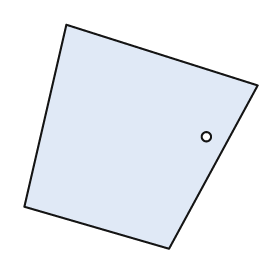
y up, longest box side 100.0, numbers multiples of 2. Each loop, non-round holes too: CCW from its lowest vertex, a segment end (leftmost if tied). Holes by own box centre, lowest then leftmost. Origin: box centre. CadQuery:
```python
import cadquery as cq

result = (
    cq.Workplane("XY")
    .moveTo(12.0, -48.0)
    .lineTo(50.0, 22.0)
    .lineTo(-32.0, 48.0)
    .lineTo(-50.0, -30.0)
    .close()
    .moveTo(28.0, 0.0)
    .circle(2.0)
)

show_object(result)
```